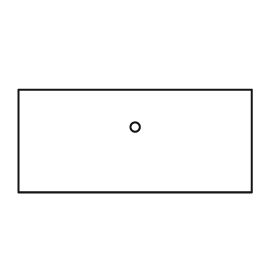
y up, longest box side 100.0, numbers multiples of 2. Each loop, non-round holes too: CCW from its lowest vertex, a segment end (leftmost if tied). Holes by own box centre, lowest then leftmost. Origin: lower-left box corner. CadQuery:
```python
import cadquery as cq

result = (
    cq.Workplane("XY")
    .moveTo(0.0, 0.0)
    .lineTo(100.0, 0.0)
    .lineTo(100.0, 44.0)
    .lineTo(0.0, 44.0)
    .close()
    .moveTo(50.0, 28.0)
    .circle(2.0)
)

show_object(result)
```